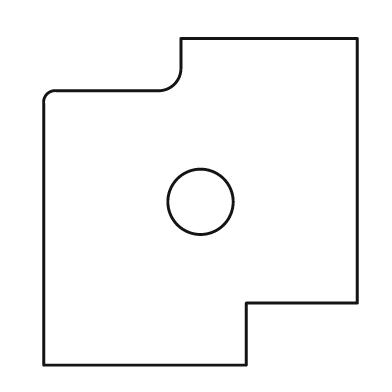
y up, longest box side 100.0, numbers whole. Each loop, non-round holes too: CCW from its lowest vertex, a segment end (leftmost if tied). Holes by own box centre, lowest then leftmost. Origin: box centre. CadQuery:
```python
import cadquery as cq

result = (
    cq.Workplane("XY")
    .moveTo(-48.0, -50.0)
    .lineTo(14.0, -50.0)
    .lineTo(14.0, -31.0)
    .lineTo(48.0, -31.0)
    .lineTo(48.0, 50.0)
    .lineTo(-6.0, 50.0)
    .lineTo(-6.0, 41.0)
    .threePointArc((-8.0, 36.0), (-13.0, 34.0))
    .lineTo(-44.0, 34.0)
    .threePointArc((-47.0, 33.0), (-48.0, 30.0))
    .close()
    .moveTo(0.0, 0.0)
    .circle(10.0)
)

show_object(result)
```